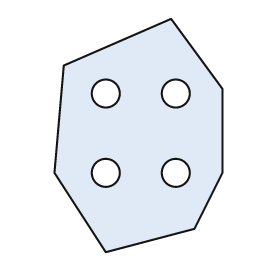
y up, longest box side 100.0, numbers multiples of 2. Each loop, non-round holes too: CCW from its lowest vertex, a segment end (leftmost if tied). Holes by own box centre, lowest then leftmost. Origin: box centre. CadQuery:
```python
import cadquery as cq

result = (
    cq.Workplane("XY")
    .moveTo(-14.0, -50.0)
    .lineTo(24.0, -40.0)
    .lineTo(36.0, -16.0)
    .lineTo(36.0, 20.0)
    .lineTo(14.0, 50.0)
    .lineTo(-32.0, 30.0)
    .lineTo(-36.0, -16.0)
    .close()
    .moveTo(-14.0, -16.0)
    .circle(6.0)
    .moveTo(16.0, -16.0)
    .circle(6.0)
    .moveTo(-14.0, 18.0)
    .circle(6.0)
    .moveTo(16.0, 18.0)
    .circle(6.0)
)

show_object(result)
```